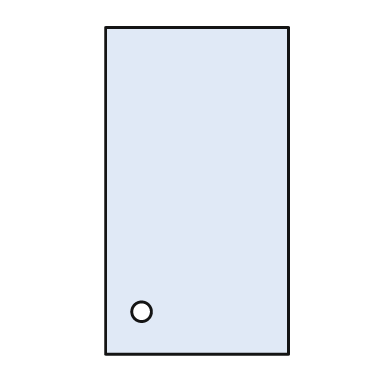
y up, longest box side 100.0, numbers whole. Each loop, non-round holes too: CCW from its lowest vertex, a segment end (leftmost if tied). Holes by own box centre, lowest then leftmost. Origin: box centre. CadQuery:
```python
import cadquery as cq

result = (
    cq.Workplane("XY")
    .moveTo(-28.0, -50.0)
    .lineTo(28.0, -50.0)
    .lineTo(28.0, 50.0)
    .lineTo(-28.0, 50.0)
    .close()
    .moveTo(-17.0, -37.0)
    .circle(3.0)
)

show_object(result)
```